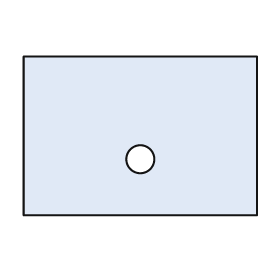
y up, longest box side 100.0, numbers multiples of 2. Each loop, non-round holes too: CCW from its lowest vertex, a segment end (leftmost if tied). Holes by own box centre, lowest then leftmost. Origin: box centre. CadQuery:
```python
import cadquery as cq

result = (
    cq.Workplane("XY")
    .moveTo(-50.0, -34.0)
    .lineTo(50.0, -34.0)
    .lineTo(50.0, 34.0)
    .lineTo(-50.0, 34.0)
    .close()
    .moveTo(0.0, -10.0)
    .circle(6.0)
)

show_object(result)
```